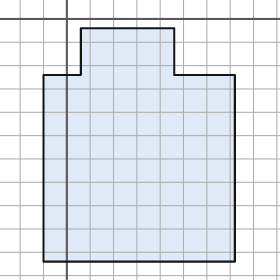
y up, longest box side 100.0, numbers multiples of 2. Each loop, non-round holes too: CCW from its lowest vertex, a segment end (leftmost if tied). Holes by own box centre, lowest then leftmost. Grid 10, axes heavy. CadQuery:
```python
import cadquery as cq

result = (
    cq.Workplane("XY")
    .moveTo(-10.0, -104.0)
    .lineTo(72.0, -104.0)
    .lineTo(72.0, -24.0)
    .lineTo(46.0, -24.0)
    .lineTo(46.0, -4.0)
    .lineTo(6.0, -4.0)
    .lineTo(6.0, -24.0)
    .lineTo(-10.0, -24.0)
    .close()
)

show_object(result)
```